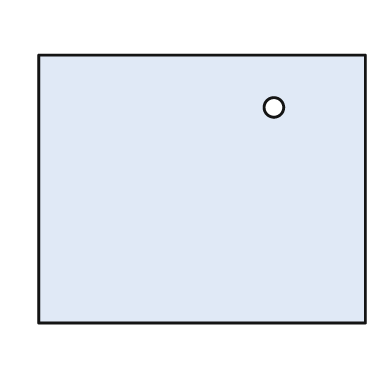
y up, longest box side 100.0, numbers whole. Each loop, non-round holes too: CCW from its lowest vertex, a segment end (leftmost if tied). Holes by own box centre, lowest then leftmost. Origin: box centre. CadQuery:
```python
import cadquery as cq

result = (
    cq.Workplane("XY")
    .moveTo(-50.0, -41.0)
    .lineTo(50.0, -41.0)
    .lineTo(50.0, 41.0)
    .lineTo(-50.0, 41.0)
    .close()
    .moveTo(22.0, 25.0)
    .circle(3.0)
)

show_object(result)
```